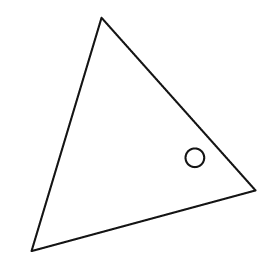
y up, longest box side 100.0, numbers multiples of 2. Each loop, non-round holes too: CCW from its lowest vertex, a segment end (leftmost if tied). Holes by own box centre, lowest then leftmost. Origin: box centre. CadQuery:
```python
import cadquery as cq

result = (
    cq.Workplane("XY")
    .moveTo(-48.0, -50.0)
    .lineTo(48.0, -24.0)
    .lineTo(-18.0, 50.0)
    .close()
    .moveTo(22.0, -10.0)
    .circle(4.0)
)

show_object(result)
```